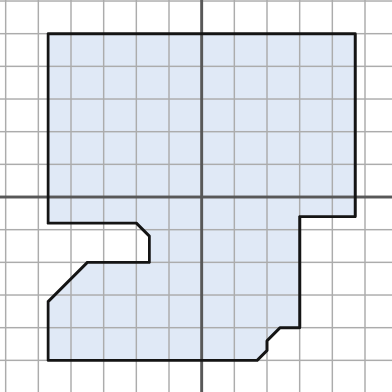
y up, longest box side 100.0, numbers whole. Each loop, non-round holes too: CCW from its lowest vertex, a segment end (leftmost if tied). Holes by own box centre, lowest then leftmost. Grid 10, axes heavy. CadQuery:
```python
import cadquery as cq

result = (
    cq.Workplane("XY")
    .moveTo(-47.0, -50.0)
    .lineTo(17.0, -50.0)
    .lineTo(20.0, -47.0)
    .lineTo(20.0, -44.0)
    .lineTo(24.0, -40.0)
    .lineTo(30.0, -40.0)
    .lineTo(30.0, -6.0)
    .lineTo(47.0, -6.0)
    .lineTo(47.0, 50.0)
    .lineTo(-47.0, 50.0)
    .lineTo(-47.0, -8.0)
    .lineTo(-20.0, -8.0)
    .lineTo(-16.0, -12.0)
    .lineTo(-16.0, -20.0)
    .lineTo(-35.0, -20.0)
    .lineTo(-47.0, -32.0)
    .close()
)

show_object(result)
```